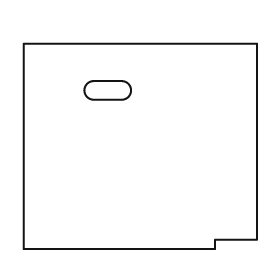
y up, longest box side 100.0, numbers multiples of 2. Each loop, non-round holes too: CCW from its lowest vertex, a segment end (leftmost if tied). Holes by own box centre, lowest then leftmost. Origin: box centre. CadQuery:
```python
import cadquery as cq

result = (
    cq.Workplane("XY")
    .moveTo(-50.0, -44.0)
    .lineTo(32.0, -44.0)
    .lineTo(32.0, -40.0)
    .lineTo(50.0, -40.0)
    .lineTo(50.0, 44.0)
    .lineTo(-50.0, 44.0)
    .close()
    .moveTo(-20.0, 20.0)
    .lineTo(-8.0, 20.0)
    .threePointArc((-4.0, 24.0), (-8.0, 28.0))
    .lineTo(-20.0, 28.0)
    .threePointArc((-24.0, 24.0), (-20.0, 20.0))
    .close()
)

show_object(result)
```